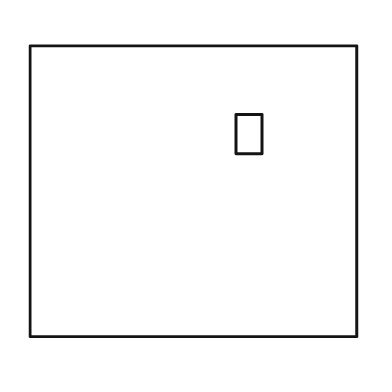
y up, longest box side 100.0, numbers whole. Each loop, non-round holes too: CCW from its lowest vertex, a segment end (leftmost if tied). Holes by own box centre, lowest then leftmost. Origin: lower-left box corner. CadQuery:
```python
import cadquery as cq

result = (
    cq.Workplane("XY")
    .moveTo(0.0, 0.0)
    .lineTo(100.0, 0.0)
    .lineTo(100.0, 89.0)
    .lineTo(0.0, 89.0)
    .close()
    .moveTo(63.0, 56.0)
    .lineTo(71.0, 56.0)
    .lineTo(71.0, 68.0)
    .lineTo(63.0, 68.0)
    .close()
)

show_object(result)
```